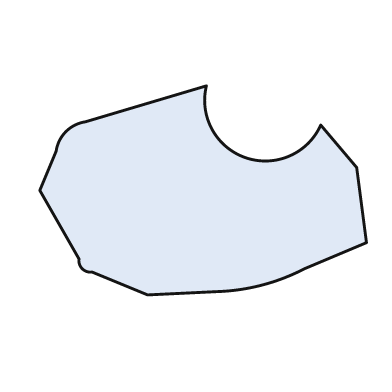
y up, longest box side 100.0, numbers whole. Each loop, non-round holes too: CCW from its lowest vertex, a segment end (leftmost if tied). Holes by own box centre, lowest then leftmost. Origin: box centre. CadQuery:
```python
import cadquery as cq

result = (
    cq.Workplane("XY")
    .moveTo(-17.0, -32.0)
    .lineTo(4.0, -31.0)
    .threePointArc((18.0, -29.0), (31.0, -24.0))
    .lineTo(50.0, -16.0)
    .lineTo(47.0, 7.0)
    .lineTo(36.0, 20.0)
    .threePointArc((13.0, 10.0), (1.0, 32.0))
    .lineTo(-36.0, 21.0)
    .threePointArc((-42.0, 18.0), (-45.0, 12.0))
    .lineTo(-50.0, 0.0)
    .lineTo(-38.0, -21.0)
    .threePointArc((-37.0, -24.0), (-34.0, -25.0))
    .close()
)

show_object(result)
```